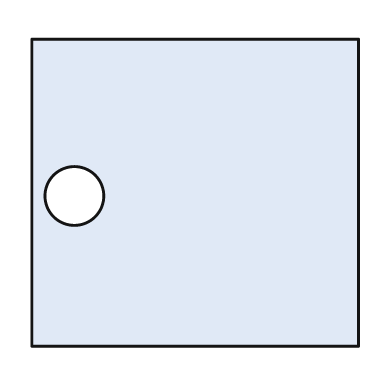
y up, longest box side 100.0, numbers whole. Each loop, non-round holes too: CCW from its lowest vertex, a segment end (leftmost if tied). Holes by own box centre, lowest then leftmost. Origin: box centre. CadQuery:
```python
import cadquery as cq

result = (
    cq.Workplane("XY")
    .moveTo(-50.0, -47.0)
    .lineTo(50.0, -47.0)
    .lineTo(50.0, 47.0)
    .lineTo(-50.0, 47.0)
    .close()
    .moveTo(-37.0, -1.0)
    .circle(9.0)
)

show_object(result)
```